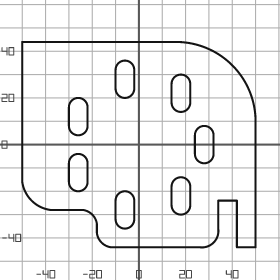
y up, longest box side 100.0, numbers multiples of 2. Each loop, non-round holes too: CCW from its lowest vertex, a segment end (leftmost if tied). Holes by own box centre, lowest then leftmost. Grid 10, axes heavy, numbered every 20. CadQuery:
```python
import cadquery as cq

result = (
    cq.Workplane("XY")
    .moveTo(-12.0, -44.0)
    .lineTo(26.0, -44.0)
    .threePointArc((32.0, -42.0), (34.0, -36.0))
    .lineTo(34.0, -24.0)
    .lineTo(42.0, -24.0)
    .lineTo(42.0, -44.0)
    .lineTo(50.0, -44.0)
    .lineTo(50.0, 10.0)
    .threePointArc((40.0, 34.0), (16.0, 44.0))
    .lineTo(-50.0, 44.0)
    .lineTo(-50.0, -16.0)
    .threePointArc((-46.0, -24.0), (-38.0, -28.0))
    .lineTo(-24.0, -28.0)
    .threePointArc((-20.0, -30.0), (-18.0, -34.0))
    .lineTo(-18.0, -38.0)
    .threePointArc((-16.0, -42.0), (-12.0, -44.0))
    .close()
    .moveTo(-10.0, -32.0)
    .threePointArc((-6.0, -36.0), (-2.0, -32.0))
    .lineTo(-2.0, -24.0)
    .threePointArc((-6.0, -20.0), (-10.0, -24.0))
    .close()
    .moveTo(14.0, -26.0)
    .threePointArc((18.0, -30.0), (22.0, -26.0))
    .lineTo(22.0, -18.0)
    .threePointArc((18.0, -14.0), (14.0, -18.0))
    .close()
    .moveTo(-30.0, -16.0)
    .threePointArc((-26.0, -20.0), (-22.0, -16.0))
    .lineTo(-22.0, -8.0)
    .threePointArc((-26.0, -4.0), (-30.0, -8.0))
    .close()
    .moveTo(24.0, -4.0)
    .threePointArc((28.0, -8.0), (32.0, -4.0))
    .lineTo(32.0, 4.0)
    .threePointArc((28.0, 8.0), (24.0, 4.0))
    .close()
    .moveTo(-30.0, 8.0)
    .threePointArc((-26.0, 4.0), (-22.0, 8.0))
    .lineTo(-22.0, 16.0)
    .threePointArc((-26.0, 20.0), (-30.0, 16.0))
    .close()
    .moveTo(14.0, 18.0)
    .threePointArc((18.0, 14.0), (22.0, 18.0))
    .lineTo(22.0, 26.0)
    .threePointArc((18.0, 30.0), (14.0, 26.0))
    .close()
    .moveTo(-10.0, 24.0)
    .threePointArc((-6.0, 20.0), (-2.0, 24.0))
    .lineTo(-2.0, 32.0)
    .threePointArc((-6.0, 36.0), (-10.0, 32.0))
    .close()
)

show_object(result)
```